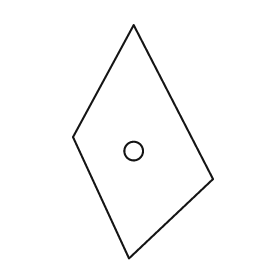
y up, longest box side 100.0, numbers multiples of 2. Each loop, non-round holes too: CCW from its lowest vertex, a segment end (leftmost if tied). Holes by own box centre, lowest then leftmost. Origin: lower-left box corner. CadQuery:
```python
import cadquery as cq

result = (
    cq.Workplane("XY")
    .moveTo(24.0, 0.0)
    .lineTo(60.0, 34.0)
    .lineTo(26.0, 100.0)
    .lineTo(0.0, 52.0)
    .close()
    .moveTo(26.0, 46.0)
    .circle(4.0)
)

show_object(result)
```